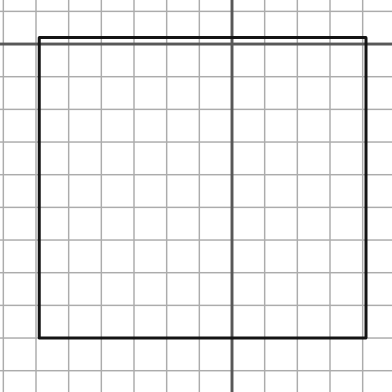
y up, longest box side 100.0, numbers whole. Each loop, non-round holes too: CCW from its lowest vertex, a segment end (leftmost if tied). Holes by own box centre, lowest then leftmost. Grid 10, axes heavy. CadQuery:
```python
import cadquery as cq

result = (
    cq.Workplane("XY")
    .moveTo(-59.0, -90.0)
    .lineTo(41.0, -90.0)
    .lineTo(41.0, 2.0)
    .lineTo(-59.0, 2.0)
    .close()
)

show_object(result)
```